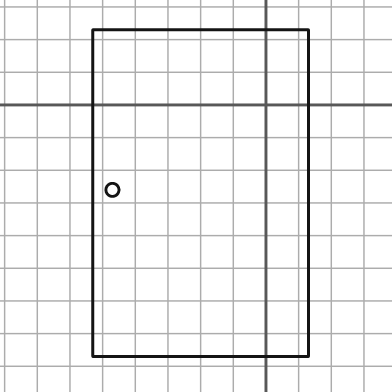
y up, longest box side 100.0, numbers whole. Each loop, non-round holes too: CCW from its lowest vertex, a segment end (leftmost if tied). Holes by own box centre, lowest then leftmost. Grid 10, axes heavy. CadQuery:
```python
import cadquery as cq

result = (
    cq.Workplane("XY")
    .moveTo(-53.0, -77.0)
    .lineTo(13.0, -77.0)
    .lineTo(13.0, 23.0)
    .lineTo(-53.0, 23.0)
    .close()
    .moveTo(-47.0, -26.0)
    .circle(2.0)
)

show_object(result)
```